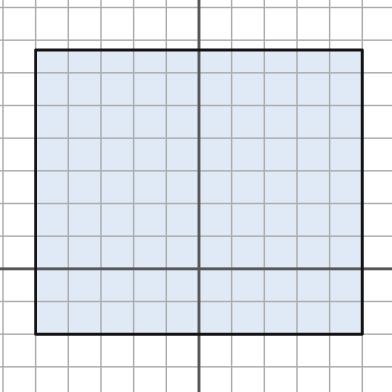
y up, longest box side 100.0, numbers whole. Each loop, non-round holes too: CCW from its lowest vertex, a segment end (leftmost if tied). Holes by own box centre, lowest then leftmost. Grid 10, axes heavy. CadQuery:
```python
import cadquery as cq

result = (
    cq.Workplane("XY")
    .moveTo(-50.0, -20.0)
    .lineTo(50.0, -20.0)
    .lineTo(50.0, 67.0)
    .lineTo(-50.0, 67.0)
    .close()
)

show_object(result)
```